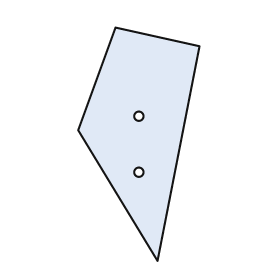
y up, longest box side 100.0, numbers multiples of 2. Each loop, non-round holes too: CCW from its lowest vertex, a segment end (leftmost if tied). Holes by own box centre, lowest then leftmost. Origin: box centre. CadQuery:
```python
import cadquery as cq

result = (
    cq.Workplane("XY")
    .moveTo(8.0, -50.0)
    .lineTo(26.0, 42.0)
    .lineTo(-10.0, 50.0)
    .lineTo(-26.0, 6.0)
    .close()
    .moveTo(0.0, -12.0)
    .circle(2.0)
    .moveTo(0.0, 12.0)
    .circle(2.0)
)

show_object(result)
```